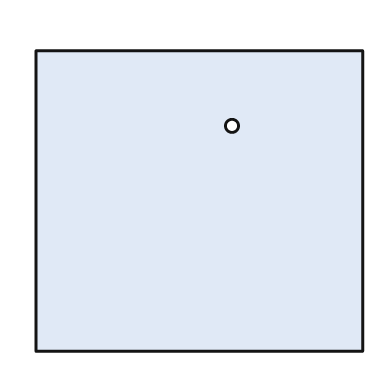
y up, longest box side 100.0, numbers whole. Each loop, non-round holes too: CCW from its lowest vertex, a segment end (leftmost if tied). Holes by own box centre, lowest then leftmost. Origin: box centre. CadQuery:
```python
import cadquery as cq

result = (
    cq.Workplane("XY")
    .moveTo(-50.0, -46.0)
    .lineTo(50.0, -46.0)
    .lineTo(50.0, 46.0)
    .lineTo(-50.0, 46.0)
    .close()
    .moveTo(10.0, 23.0)
    .circle(2.0)
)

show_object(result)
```